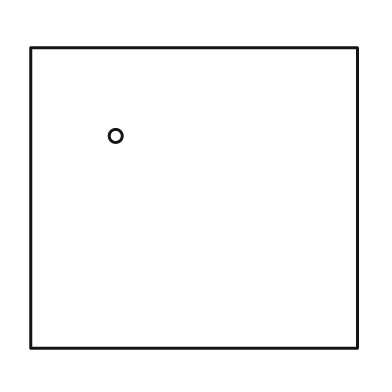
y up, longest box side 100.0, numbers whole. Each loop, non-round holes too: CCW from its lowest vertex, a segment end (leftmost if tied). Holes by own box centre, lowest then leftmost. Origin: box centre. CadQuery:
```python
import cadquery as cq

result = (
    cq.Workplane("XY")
    .moveTo(-50.0, -46.0)
    .lineTo(50.0, -46.0)
    .lineTo(50.0, 46.0)
    .lineTo(-50.0, 46.0)
    .close()
    .moveTo(-24.0, 19.0)
    .circle(2.0)
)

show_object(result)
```